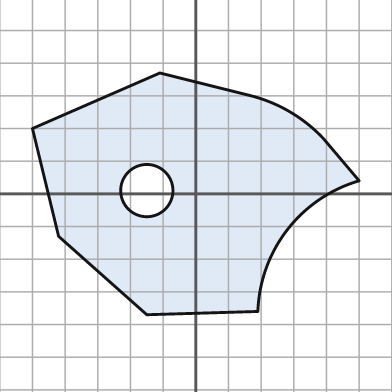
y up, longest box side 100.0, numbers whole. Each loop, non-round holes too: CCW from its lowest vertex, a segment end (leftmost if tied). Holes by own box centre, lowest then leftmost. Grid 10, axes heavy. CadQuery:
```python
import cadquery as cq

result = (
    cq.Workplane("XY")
    .moveTo(-15.0, -37.0)
    .lineTo(19.0, -36.0)
    .threePointArc((28.0, -11.0), (50.0, 4.0))
    .lineTo(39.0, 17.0)
    .threePointArc((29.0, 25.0), (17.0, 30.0))
    .lineTo(-11.0, 37.0)
    .lineTo(-50.0, 20.0)
    .lineTo(-42.0, -13.0)
    .close()
    .moveTo(-15.0, 1.0)
    .circle(8.0)
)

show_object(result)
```